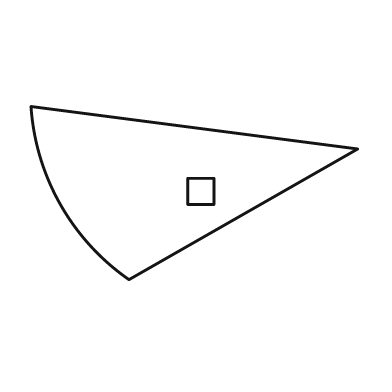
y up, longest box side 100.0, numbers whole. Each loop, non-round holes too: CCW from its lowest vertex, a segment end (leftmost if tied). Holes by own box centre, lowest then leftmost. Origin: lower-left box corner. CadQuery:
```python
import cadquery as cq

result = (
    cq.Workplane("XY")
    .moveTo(30.0, 0.0)
    .lineTo(100.0, 40.0)
    .lineTo(0.0, 53.0)
    .threePointArc((9.0, 23.0), (30.0, 0.0))
    .close()
    .moveTo(48.0, 23.0)
    .lineTo(56.0, 23.0)
    .lineTo(56.0, 31.0)
    .lineTo(48.0, 31.0)
    .close()
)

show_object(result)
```